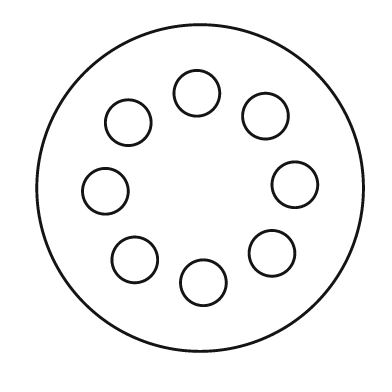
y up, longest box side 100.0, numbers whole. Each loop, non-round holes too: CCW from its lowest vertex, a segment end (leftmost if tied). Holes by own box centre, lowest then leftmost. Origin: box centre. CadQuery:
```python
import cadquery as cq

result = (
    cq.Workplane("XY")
    .moveTo(0.0, 0.0)
    .circle(50.0)
    .moveTo(1.0, -29.0)
    .circle(7.0)
    .moveTo(-20.0, -22.0)
    .circle(7.0)
    .moveTo(22.0, -20.0)
    .circle(7.0)
    .moveTo(-29.0, -1.0)
    .circle(7.0)
    .moveTo(29.0, 1.0)
    .circle(7.0)
    .moveTo(-22.0, 20.0)
    .circle(7.0)
    .moveTo(20.0, 22.0)
    .circle(7.0)
    .moveTo(-1.0, 29.0)
    .circle(7.0)
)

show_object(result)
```